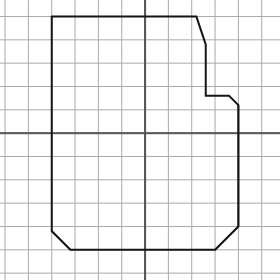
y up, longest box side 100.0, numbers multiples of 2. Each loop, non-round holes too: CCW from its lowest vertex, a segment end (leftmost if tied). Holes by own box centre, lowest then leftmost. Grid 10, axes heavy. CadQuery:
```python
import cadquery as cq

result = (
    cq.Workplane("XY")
    .moveTo(-32.0, -50.0)
    .lineTo(30.0, -50.0)
    .lineTo(40.0, -40.0)
    .lineTo(40.0, 12.0)
    .lineTo(36.0, 16.0)
    .lineTo(26.0, 16.0)
    .lineTo(26.0, 38.0)
    .lineTo(22.0, 50.0)
    .lineTo(-40.0, 50.0)
    .lineTo(-40.0, -42.0)
    .close()
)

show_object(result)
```